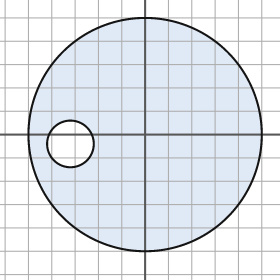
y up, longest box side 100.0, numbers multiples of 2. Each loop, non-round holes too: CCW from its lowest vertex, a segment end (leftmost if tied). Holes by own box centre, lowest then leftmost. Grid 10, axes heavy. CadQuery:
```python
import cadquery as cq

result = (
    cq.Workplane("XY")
    .moveTo(0.0, 0.0)
    .circle(50.0)
    .moveTo(-32.0, -4.0)
    .circle(10.0)
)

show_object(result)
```